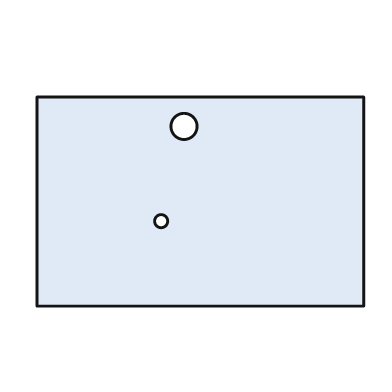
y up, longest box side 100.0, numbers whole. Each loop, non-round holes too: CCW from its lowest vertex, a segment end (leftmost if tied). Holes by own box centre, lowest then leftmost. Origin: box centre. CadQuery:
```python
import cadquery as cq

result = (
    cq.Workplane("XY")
    .moveTo(-50.0, -32.0)
    .lineTo(50.0, -32.0)
    .lineTo(50.0, 32.0)
    .lineTo(-50.0, 32.0)
    .close()
    .moveTo(-12.0, -6.0)
    .circle(2.0)
    .moveTo(-5.0, 23.0)
    .circle(4.0)
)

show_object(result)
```